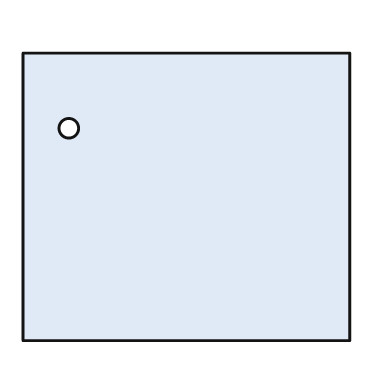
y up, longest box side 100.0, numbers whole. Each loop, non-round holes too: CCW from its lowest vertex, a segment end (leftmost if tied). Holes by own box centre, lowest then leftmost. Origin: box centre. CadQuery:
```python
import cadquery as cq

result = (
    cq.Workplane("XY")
    .moveTo(-50.0, -44.0)
    .lineTo(50.0, -44.0)
    .lineTo(50.0, 44.0)
    .lineTo(-50.0, 44.0)
    .close()
    .moveTo(-36.0, 21.0)
    .circle(3.0)
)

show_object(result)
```